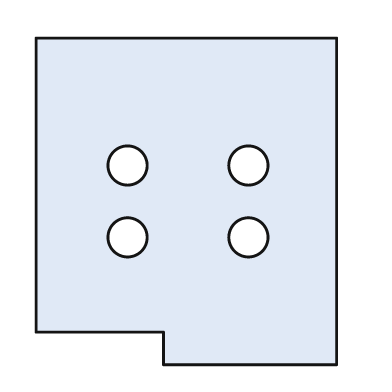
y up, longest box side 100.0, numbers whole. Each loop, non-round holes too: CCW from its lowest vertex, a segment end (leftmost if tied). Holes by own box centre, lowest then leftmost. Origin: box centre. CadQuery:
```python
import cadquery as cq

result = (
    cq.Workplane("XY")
    .moveTo(-7.0, -50.0)
    .lineTo(46.0, -50.0)
    .lineTo(46.0, 50.0)
    .lineTo(-46.0, 50.0)
    .lineTo(-46.0, -40.0)
    .lineTo(-7.0, -40.0)
    .close()
    .moveTo(-18.0, -11.0)
    .circle(6.0)
    .moveTo(19.0, -11.0)
    .circle(6.0)
    .moveTo(-18.0, 11.0)
    .circle(6.0)
    .moveTo(19.0, 11.0)
    .circle(6.0)
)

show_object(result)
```